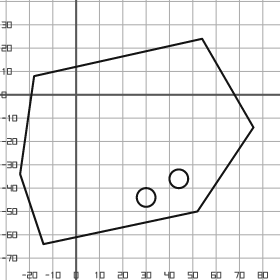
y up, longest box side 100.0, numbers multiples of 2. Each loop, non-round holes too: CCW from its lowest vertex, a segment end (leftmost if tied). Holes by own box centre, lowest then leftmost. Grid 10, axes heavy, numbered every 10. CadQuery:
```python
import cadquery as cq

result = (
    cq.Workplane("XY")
    .moveTo(-14.0, -64.0)
    .lineTo(52.0, -50.0)
    .lineTo(76.0, -14.0)
    .lineTo(54.0, 24.0)
    .lineTo(-18.0, 8.0)
    .lineTo(-24.0, -34.0)
    .close()
    .moveTo(30.0, -44.0)
    .circle(4.0)
    .moveTo(44.0, -36.0)
    .circle(4.0)
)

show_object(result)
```